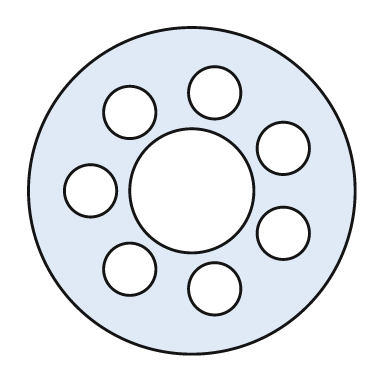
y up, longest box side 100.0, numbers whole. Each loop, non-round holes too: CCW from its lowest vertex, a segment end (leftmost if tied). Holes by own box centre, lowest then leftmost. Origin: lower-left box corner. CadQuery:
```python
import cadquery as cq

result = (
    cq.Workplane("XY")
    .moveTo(50.0, 50.0)
    .circle(50.0)
    .moveTo(57.0, 20.0)
    .circle(8.0)
    .moveTo(31.0, 26.0)
    .circle(8.0)
    .moveTo(78.0, 37.0)
    .circle(8.0)
    .moveTo(19.0, 50.0)
    .circle(8.0)
    .moveTo(50.0, 50.0)
    .circle(19.0)
    .moveTo(78.0, 63.0)
    .circle(8.0)
    .moveTo(31.0, 74.0)
    .circle(8.0)
    .moveTo(57.0, 80.0)
    .circle(8.0)
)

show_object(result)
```